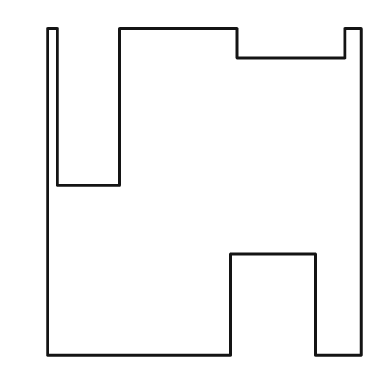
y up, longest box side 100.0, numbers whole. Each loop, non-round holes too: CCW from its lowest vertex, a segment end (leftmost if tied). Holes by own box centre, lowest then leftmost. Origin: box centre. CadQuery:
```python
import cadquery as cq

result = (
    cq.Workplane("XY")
    .moveTo(-48.0, -50.0)
    .lineTo(8.0, -50.0)
    .lineTo(8.0, -19.0)
    .lineTo(34.0, -19.0)
    .lineTo(34.0, -50.0)
    .lineTo(48.0, -50.0)
    .lineTo(48.0, 50.0)
    .lineTo(43.0, 50.0)
    .lineTo(43.0, 41.0)
    .lineTo(10.0, 41.0)
    .lineTo(10.0, 50.0)
    .lineTo(-26.0, 50.0)
    .lineTo(-26.0, 2.0)
    .lineTo(-45.0, 2.0)
    .lineTo(-45.0, 50.0)
    .lineTo(-48.0, 50.0)
    .close()
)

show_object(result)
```